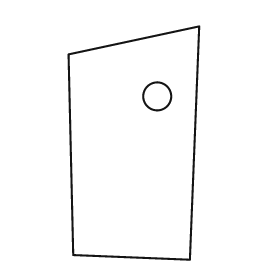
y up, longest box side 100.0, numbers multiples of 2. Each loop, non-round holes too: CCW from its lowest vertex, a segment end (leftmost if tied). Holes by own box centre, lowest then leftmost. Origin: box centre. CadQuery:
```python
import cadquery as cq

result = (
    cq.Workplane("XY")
    .moveTo(24.0, -50.0)
    .lineTo(28.0, 50.0)
    .lineTo(-28.0, 38.0)
    .lineTo(-26.0, -48.0)
    .close()
    .moveTo(10.0, 20.0)
    .circle(6.0)
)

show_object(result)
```